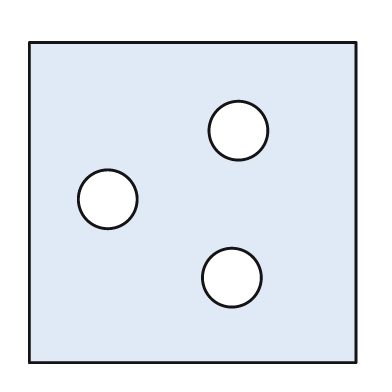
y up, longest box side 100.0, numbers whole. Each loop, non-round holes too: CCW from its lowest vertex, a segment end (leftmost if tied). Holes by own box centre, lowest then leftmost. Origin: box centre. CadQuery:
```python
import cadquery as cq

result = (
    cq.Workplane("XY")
    .moveTo(-50.0, -49.0)
    .lineTo(50.0, -49.0)
    .lineTo(50.0, 49.0)
    .lineTo(-50.0, 49.0)
    .close()
    .moveTo(12.0, -23.0)
    .circle(9.0)
    .moveTo(-26.0, 1.0)
    .circle(9.0)
    .moveTo(14.0, 22.0)
    .circle(9.0)
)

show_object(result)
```